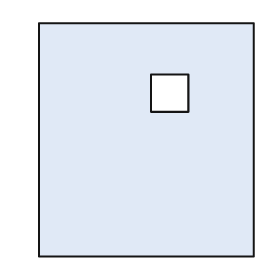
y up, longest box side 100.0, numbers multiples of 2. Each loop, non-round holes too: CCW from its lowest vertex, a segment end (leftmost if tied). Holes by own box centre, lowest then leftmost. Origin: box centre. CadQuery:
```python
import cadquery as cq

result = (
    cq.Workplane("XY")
    .moveTo(-46.0, -50.0)
    .lineTo(46.0, -50.0)
    .lineTo(46.0, 50.0)
    .lineTo(-46.0, 50.0)
    .close()
    .moveTo(2.0, 12.0)
    .lineTo(18.0, 12.0)
    .lineTo(18.0, 28.0)
    .lineTo(2.0, 28.0)
    .close()
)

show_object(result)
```